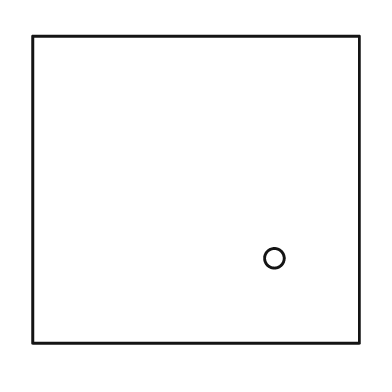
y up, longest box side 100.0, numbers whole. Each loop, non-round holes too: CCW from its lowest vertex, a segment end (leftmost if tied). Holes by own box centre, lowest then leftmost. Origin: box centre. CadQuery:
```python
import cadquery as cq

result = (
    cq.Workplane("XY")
    .moveTo(-50.0, -47.0)
    .lineTo(50.0, -47.0)
    .lineTo(50.0, 47.0)
    .lineTo(-50.0, 47.0)
    .close()
    .moveTo(24.0, -21.0)
    .circle(3.0)
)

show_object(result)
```